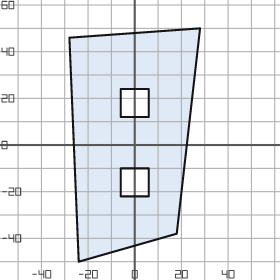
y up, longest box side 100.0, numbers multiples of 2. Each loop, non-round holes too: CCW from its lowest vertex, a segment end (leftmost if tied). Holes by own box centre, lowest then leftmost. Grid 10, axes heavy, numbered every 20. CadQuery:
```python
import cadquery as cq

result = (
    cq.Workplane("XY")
    .moveTo(-24.0, -50.0)
    .lineTo(18.0, -38.0)
    .lineTo(28.0, 50.0)
    .lineTo(-28.0, 46.0)
    .close()
    .moveTo(-6.0, -22.0)
    .lineTo(6.0, -22.0)
    .lineTo(6.0, -10.0)
    .lineTo(-6.0, -10.0)
    .close()
    .moveTo(-6.0, 12.0)
    .lineTo(6.0, 12.0)
    .lineTo(6.0, 24.0)
    .lineTo(-6.0, 24.0)
    .close()
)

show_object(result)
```